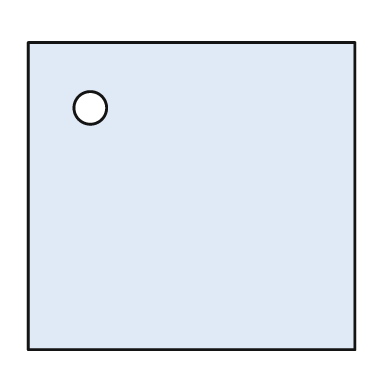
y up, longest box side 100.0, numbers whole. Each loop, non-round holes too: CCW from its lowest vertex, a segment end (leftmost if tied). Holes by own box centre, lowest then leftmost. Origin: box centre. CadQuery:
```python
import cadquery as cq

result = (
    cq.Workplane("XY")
    .moveTo(-50.0, -47.0)
    .lineTo(50.0, -47.0)
    .lineTo(50.0, 47.0)
    .lineTo(-50.0, 47.0)
    .close()
    .moveTo(-31.0, 27.0)
    .circle(5.0)
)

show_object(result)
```